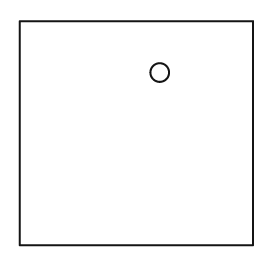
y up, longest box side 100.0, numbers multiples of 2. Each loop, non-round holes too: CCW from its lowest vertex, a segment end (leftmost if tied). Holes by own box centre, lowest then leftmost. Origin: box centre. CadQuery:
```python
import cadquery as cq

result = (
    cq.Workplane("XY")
    .moveTo(-50.0, -48.0)
    .lineTo(50.0, -48.0)
    .lineTo(50.0, 48.0)
    .lineTo(-50.0, 48.0)
    .close()
    .moveTo(10.0, 26.0)
    .circle(4.0)
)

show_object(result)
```